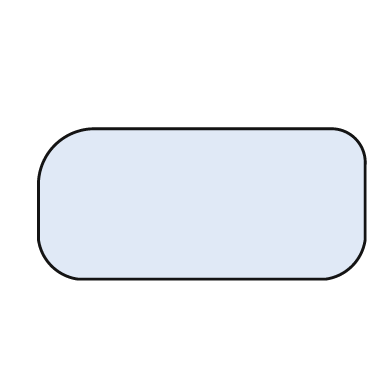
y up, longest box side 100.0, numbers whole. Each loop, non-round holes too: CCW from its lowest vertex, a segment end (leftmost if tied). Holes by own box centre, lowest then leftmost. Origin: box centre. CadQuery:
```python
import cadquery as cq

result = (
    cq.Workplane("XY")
    .moveTo(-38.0, -23.0)
    .lineTo(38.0, -23.0)
    .threePointArc((46.0, -19.0), (50.0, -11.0))
    .lineTo(50.0, 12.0)
    .threePointArc((47.0, 20.0), (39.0, 23.0))
    .lineTo(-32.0, 23.0)
    .threePointArc((-45.0, 18.0), (-50.0, 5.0))
    .lineTo(-50.0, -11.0)
    .threePointArc((-46.0, -19.0), (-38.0, -23.0))
    .close()
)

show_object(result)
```